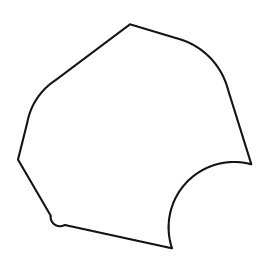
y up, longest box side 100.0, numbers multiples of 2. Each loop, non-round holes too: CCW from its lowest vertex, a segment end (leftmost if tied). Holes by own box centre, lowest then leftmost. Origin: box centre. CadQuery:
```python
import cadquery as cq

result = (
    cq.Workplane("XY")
    .moveTo(16.0, -48.0)
    .threePointArc((22.0, -20.0), (50.0, -12.0))
    .lineTo(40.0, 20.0)
    .threePointArc((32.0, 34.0), (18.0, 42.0))
    .lineTo(-2.0, 48.0)
    .lineTo(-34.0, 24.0)
    .threePointArc((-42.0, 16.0), (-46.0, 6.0))
    .lineTo(-50.0, -10.0)
    .lineTo(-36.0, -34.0)
    .threePointArc((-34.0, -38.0), (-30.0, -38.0))
    .close()
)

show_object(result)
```